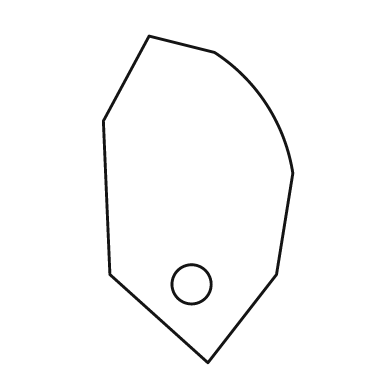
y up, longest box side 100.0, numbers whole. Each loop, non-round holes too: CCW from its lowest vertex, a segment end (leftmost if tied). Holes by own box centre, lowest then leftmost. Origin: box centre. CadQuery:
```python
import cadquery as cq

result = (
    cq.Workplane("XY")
    .moveTo(3.0, -50.0)
    .lineTo(24.0, -23.0)
    .lineTo(29.0, 8.0)
    .threePointArc((21.0, 29.0), (5.0, 45.0))
    .lineTo(-15.0, 50.0)
    .lineTo(-29.0, 24.0)
    .lineTo(-27.0, -23.0)
    .close()
    .moveTo(-2.0, -26.0)
    .circle(6.0)
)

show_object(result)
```